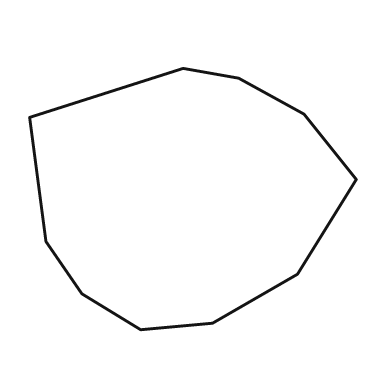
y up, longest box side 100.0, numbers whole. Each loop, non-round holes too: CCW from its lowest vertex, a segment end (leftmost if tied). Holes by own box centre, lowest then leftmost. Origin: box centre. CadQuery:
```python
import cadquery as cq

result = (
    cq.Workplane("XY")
    .moveTo(-16.0, -40.0)
    .lineTo(6.0, -38.0)
    .lineTo(32.0, -23.0)
    .lineTo(50.0, 6.0)
    .lineTo(34.0, 26.0)
    .lineTo(14.0, 37.0)
    .lineTo(-3.0, 40.0)
    .lineTo(-50.0, 25.0)
    .lineTo(-45.0, -13.0)
    .lineTo(-34.0, -29.0)
    .close()
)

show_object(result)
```